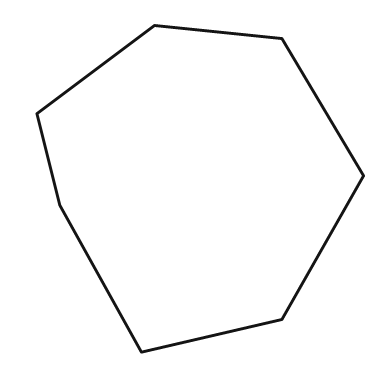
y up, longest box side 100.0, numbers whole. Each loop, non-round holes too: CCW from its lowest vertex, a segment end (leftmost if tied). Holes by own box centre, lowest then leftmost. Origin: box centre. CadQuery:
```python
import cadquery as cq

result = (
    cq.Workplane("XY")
    .moveTo(-18.0, -50.0)
    .lineTo(25.0, -40.0)
    .lineTo(50.0, 4.0)
    .lineTo(25.0, 46.0)
    .lineTo(-14.0, 50.0)
    .lineTo(-50.0, 23.0)
    .lineTo(-43.0, -5.0)
    .close()
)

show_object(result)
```